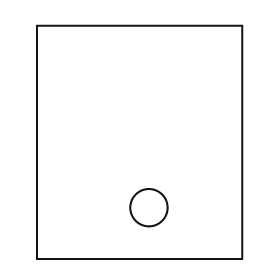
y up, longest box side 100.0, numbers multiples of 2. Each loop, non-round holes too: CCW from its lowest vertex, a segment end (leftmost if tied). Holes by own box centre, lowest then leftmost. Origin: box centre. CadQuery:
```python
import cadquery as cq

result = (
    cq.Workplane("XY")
    .moveTo(-44.0, -50.0)
    .lineTo(44.0, -50.0)
    .lineTo(44.0, 50.0)
    .lineTo(-44.0, 50.0)
    .close()
    .moveTo(4.0, -28.0)
    .circle(8.0)
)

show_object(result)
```